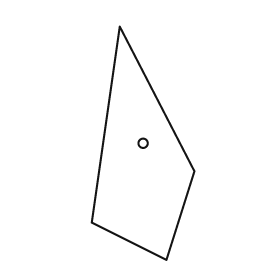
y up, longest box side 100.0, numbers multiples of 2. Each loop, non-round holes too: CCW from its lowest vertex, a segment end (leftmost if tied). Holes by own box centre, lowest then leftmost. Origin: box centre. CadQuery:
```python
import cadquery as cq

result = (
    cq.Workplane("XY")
    .moveTo(10.0, -50.0)
    .lineTo(22.0, -12.0)
    .lineTo(-10.0, 50.0)
    .lineTo(-22.0, -34.0)
    .close()
    .moveTo(0.0, 0.0)
    .circle(2.0)
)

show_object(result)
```